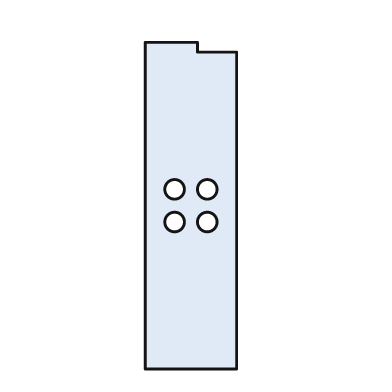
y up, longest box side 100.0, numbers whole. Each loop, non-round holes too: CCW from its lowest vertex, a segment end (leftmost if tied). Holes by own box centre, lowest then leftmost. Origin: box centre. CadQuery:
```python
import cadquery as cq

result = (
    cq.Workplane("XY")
    .moveTo(-14.0, -50.0)
    .lineTo(14.0, -50.0)
    .lineTo(14.0, 47.0)
    .lineTo(2.0, 47.0)
    .lineTo(2.0, 50.0)
    .lineTo(-14.0, 50.0)
    .close()
    .moveTo(-5.0, -5.0)
    .circle(3.0)
    .moveTo(5.0, -5.0)
    .circle(3.0)
    .moveTo(-5.0, 5.0)
    .circle(3.0)
    .moveTo(5.0, 5.0)
    .circle(3.0)
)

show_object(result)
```